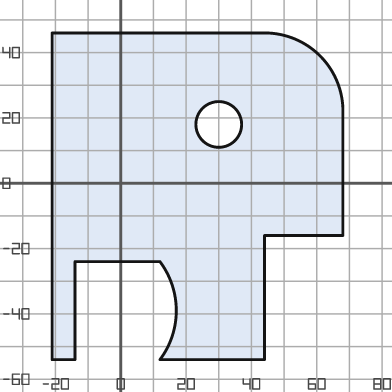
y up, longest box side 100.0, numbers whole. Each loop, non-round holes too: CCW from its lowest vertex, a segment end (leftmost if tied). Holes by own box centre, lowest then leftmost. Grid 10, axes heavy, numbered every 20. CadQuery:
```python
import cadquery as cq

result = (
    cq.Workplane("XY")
    .moveTo(-21.0, -54.0)
    .lineTo(-14.0, -54.0)
    .lineTo(-14.0, -24.0)
    .lineTo(12.0, -24.0)
    .threePointArc((17.0, -39.0), (12.0, -54.0))
    .lineTo(44.0, -54.0)
    .lineTo(44.0, -16.0)
    .lineTo(68.0, -16.0)
    .lineTo(68.0, 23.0)
    .threePointArc((61.0, 39.0), (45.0, 46.0))
    .lineTo(-21.0, 46.0)
    .close()
    .moveTo(30.0, 18.0)
    .circle(7.0)
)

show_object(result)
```